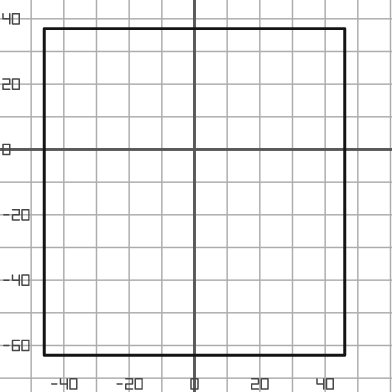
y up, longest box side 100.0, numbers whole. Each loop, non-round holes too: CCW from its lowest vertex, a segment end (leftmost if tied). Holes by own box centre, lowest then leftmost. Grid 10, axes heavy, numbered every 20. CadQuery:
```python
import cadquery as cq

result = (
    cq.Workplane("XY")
    .moveTo(-46.0, -63.0)
    .lineTo(46.0, -63.0)
    .lineTo(46.0, 37.0)
    .lineTo(-46.0, 37.0)
    .close()
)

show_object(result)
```